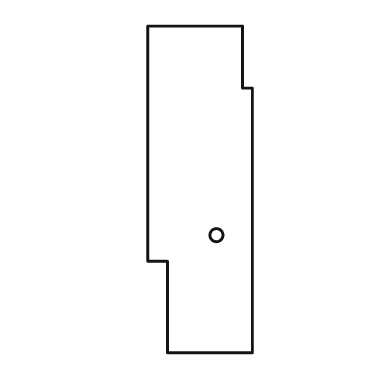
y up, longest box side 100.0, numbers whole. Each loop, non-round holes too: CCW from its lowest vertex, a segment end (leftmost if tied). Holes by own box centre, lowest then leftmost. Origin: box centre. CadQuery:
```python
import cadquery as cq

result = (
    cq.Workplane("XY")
    .moveTo(-10.0, -50.0)
    .lineTo(16.0, -50.0)
    .lineTo(16.0, 31.0)
    .lineTo(13.0, 31.0)
    .lineTo(13.0, 50.0)
    .lineTo(-16.0, 50.0)
    .lineTo(-16.0, -22.0)
    .lineTo(-10.0, -22.0)
    .close()
    .moveTo(5.0, -14.0)
    .circle(2.0)
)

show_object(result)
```